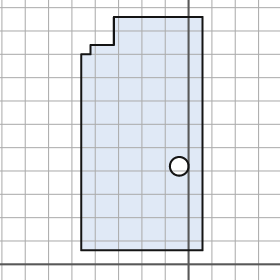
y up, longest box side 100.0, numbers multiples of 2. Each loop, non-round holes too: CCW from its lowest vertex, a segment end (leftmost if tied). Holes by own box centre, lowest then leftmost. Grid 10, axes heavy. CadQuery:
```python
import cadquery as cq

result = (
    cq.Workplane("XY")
    .moveTo(-46.0, 6.0)
    .lineTo(6.0, 6.0)
    .lineTo(6.0, 106.0)
    .lineTo(-32.0, 106.0)
    .lineTo(-32.0, 94.0)
    .lineTo(-42.0, 94.0)
    .lineTo(-42.0, 90.0)
    .lineTo(-46.0, 90.0)
    .close()
    .moveTo(-4.0, 42.0)
    .circle(4.0)
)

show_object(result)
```